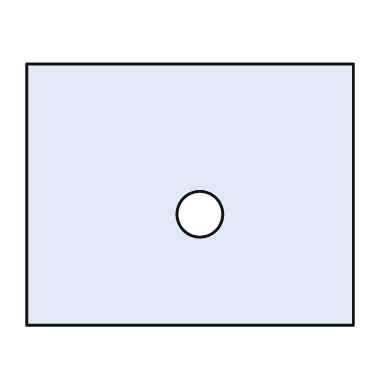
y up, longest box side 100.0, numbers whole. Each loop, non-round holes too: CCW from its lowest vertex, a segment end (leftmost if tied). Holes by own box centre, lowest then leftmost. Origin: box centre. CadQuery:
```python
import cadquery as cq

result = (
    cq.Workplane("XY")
    .moveTo(-50.0, -40.0)
    .lineTo(50.0, -40.0)
    .lineTo(50.0, 40.0)
    .lineTo(-50.0, 40.0)
    .close()
    .moveTo(3.0, -6.0)
    .circle(7.0)
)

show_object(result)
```